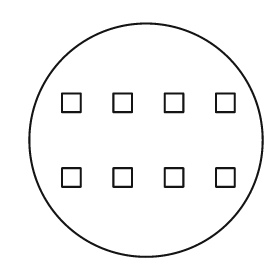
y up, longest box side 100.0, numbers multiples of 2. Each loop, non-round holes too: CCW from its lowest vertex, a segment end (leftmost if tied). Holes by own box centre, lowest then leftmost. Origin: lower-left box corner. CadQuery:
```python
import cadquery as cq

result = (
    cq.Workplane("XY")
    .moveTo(50.0, 50.0)
    .circle(50.0)
    .moveTo(14.0, 30.0)
    .lineTo(22.0, 30.0)
    .lineTo(22.0, 38.0)
    .lineTo(14.0, 38.0)
    .close()
    .moveTo(36.0, 30.0)
    .lineTo(44.0, 30.0)
    .lineTo(44.0, 38.0)
    .lineTo(36.0, 38.0)
    .close()
    .moveTo(58.0, 30.0)
    .lineTo(66.0, 30.0)
    .lineTo(66.0, 38.0)
    .lineTo(58.0, 38.0)
    .close()
    .moveTo(80.0, 30.0)
    .lineTo(88.0, 30.0)
    .lineTo(88.0, 38.0)
    .lineTo(80.0, 38.0)
    .close()
    .moveTo(14.0, 62.0)
    .lineTo(22.0, 62.0)
    .lineTo(22.0, 70.0)
    .lineTo(14.0, 70.0)
    .close()
    .moveTo(36.0, 62.0)
    .lineTo(44.0, 62.0)
    .lineTo(44.0, 70.0)
    .lineTo(36.0, 70.0)
    .close()
    .moveTo(58.0, 62.0)
    .lineTo(66.0, 62.0)
    .lineTo(66.0, 70.0)
    .lineTo(58.0, 70.0)
    .close()
    .moveTo(80.0, 62.0)
    .lineTo(88.0, 62.0)
    .lineTo(88.0, 70.0)
    .lineTo(80.0, 70.0)
    .close()
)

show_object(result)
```